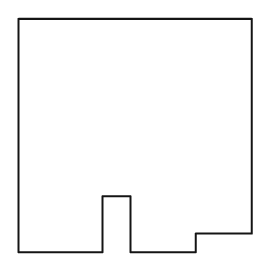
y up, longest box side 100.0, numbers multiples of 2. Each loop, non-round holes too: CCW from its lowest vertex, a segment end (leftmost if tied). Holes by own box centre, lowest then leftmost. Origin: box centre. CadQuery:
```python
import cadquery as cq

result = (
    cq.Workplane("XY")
    .moveTo(-50.0, -50.0)
    .lineTo(-14.0, -50.0)
    .lineTo(-14.0, -26.0)
    .lineTo(-2.0, -26.0)
    .lineTo(-2.0, -50.0)
    .lineTo(26.0, -50.0)
    .lineTo(26.0, -42.0)
    .lineTo(50.0, -42.0)
    .lineTo(50.0, 50.0)
    .lineTo(-50.0, 50.0)
    .close()
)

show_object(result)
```